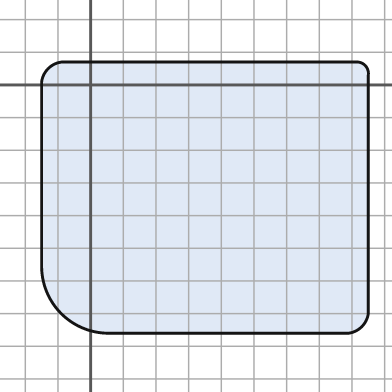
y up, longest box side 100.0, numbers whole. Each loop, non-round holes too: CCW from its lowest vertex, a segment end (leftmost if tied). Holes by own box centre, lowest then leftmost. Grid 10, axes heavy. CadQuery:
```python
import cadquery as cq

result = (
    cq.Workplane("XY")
    .moveTo(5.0, -76.0)
    .lineTo(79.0, -76.0)
    .threePointArc((83.0, -74.0), (85.0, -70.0))
    .lineTo(85.0, 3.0)
    .threePointArc((84.0, 6.0), (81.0, 7.0))
    .lineTo(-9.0, 7.0)
    .threePointArc((-13.0, 5.0), (-15.0, 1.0))
    .lineTo(-15.0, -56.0)
    .threePointArc((-9.0, -70.0), (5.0, -76.0))
    .close()
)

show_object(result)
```